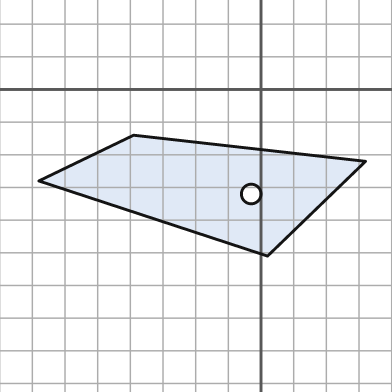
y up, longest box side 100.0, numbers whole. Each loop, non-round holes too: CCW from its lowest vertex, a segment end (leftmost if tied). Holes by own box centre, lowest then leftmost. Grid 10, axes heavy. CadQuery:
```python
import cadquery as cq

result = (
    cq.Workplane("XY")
    .moveTo(2.0, -51.0)
    .lineTo(32.0, -22.0)
    .lineTo(-39.0, -14.0)
    .lineTo(-68.0, -28.0)
    .close()
    .moveTo(-3.0, -32.0)
    .circle(3.0)
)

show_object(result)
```